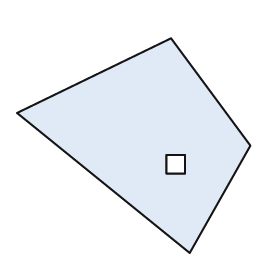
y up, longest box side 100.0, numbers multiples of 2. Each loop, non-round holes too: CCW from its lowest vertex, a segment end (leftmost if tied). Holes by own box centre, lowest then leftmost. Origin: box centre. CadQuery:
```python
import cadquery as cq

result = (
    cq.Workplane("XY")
    .moveTo(24.0, -46.0)
    .lineTo(50.0, 0.0)
    .lineTo(16.0, 46.0)
    .lineTo(-50.0, 14.0)
    .close()
    .moveTo(14.0, -12.0)
    .lineTo(22.0, -12.0)
    .lineTo(22.0, -4.0)
    .lineTo(14.0, -4.0)
    .close()
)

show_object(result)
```